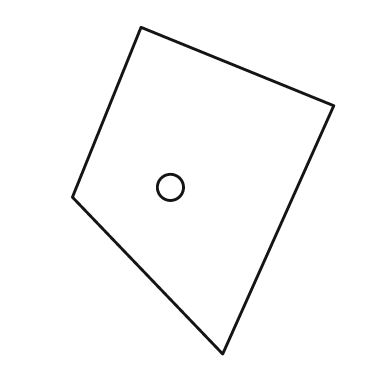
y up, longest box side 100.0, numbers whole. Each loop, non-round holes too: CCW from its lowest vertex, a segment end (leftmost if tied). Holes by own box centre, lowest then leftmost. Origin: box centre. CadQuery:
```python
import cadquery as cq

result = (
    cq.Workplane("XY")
    .moveTo(6.0, -50.0)
    .lineTo(40.0, 26.0)
    .lineTo(-19.0, 50.0)
    .lineTo(-40.0, -2.0)
    .close()
    .moveTo(-10.0, 1.0)
    .circle(4.0)
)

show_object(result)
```